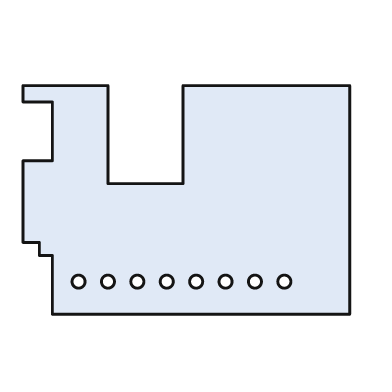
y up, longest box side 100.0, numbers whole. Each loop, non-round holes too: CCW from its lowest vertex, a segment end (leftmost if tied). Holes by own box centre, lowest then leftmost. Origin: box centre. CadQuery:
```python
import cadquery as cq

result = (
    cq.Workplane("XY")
    .moveTo(-41.0, -35.0)
    .lineTo(50.0, -35.0)
    .lineTo(50.0, 35.0)
    .lineTo(-1.0, 35.0)
    .lineTo(-1.0, 5.0)
    .lineTo(-24.0, 5.0)
    .lineTo(-24.0, 35.0)
    .lineTo(-50.0, 35.0)
    .lineTo(-50.0, 30.0)
    .lineTo(-41.0, 30.0)
    .lineTo(-41.0, 12.0)
    .lineTo(-50.0, 12.0)
    .lineTo(-50.0, -13.0)
    .lineTo(-45.0, -13.0)
    .lineTo(-45.0, -17.0)
    .lineTo(-41.0, -17.0)
    .close()
    .moveTo(-33.0, -25.0)
    .circle(2.0)
    .moveTo(-24.0, -25.0)
    .circle(2.0)
    .moveTo(-15.0, -25.0)
    .circle(2.0)
    .moveTo(-6.0, -25.0)
    .circle(2.0)
    .moveTo(3.0, -25.0)
    .circle(2.0)
    .moveTo(12.0, -25.0)
    .circle(2.0)
    .moveTo(21.0, -25.0)
    .circle(2.0)
    .moveTo(30.0, -25.0)
    .circle(2.0)
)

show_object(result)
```